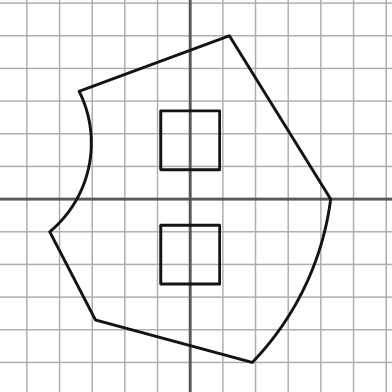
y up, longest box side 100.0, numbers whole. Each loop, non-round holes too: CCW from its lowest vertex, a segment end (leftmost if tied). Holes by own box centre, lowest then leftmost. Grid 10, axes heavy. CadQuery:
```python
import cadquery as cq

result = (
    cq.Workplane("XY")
    .moveTo(19.0, -50.0)
    .threePointArc((35.0, -27.0), (43.0, 0.0))
    .lineTo(12.0, 50.0)
    .lineTo(-34.0, 33.0)
    .threePointArc((-31.0, 10.0), (-43.0, -10.0))
    .lineTo(-29.0, -37.0)
    .close()
    .moveTo(-9.0, -26.0)
    .lineTo(9.0, -26.0)
    .lineTo(9.0, -8.0)
    .lineTo(-9.0, -8.0)
    .close()
    .moveTo(-9.0, 9.0)
    .lineTo(9.0, 9.0)
    .lineTo(9.0, 27.0)
    .lineTo(-9.0, 27.0)
    .close()
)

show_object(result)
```